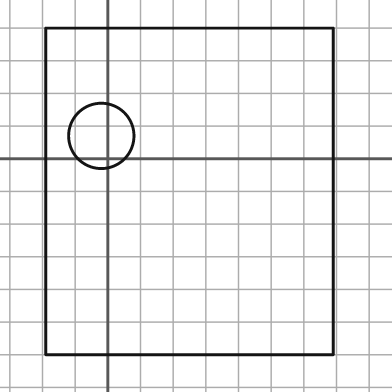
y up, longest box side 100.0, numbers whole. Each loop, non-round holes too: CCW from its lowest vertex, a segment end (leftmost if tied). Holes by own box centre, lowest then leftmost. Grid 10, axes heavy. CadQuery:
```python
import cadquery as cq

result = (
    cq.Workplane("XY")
    .moveTo(-19.0, -60.0)
    .lineTo(69.0, -60.0)
    .lineTo(69.0, 40.0)
    .lineTo(-19.0, 40.0)
    .close()
    .moveTo(-2.0, 7.0)
    .circle(10.0)
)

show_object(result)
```